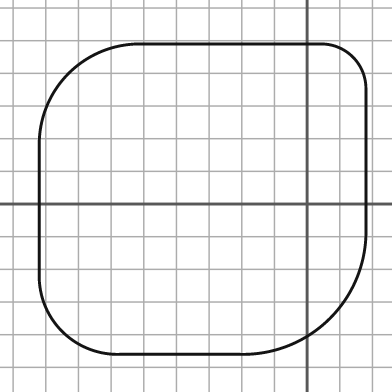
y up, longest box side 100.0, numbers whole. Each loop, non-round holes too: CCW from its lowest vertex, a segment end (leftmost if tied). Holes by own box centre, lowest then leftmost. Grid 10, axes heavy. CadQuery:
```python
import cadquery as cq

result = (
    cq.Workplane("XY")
    .moveTo(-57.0, -46.0)
    .lineTo(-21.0, -46.0)
    .threePointArc((7.0, -35.0), (18.0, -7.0))
    .lineTo(18.0, 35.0)
    .threePointArc((14.0, 45.0), (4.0, 49.0))
    .lineTo(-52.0, 49.0)
    .threePointArc((-73.0, 40.0), (-82.0, 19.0))
    .lineTo(-82.0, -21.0)
    .threePointArc((-75.0, -39.0), (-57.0, -46.0))
    .close()
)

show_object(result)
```